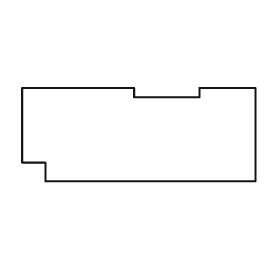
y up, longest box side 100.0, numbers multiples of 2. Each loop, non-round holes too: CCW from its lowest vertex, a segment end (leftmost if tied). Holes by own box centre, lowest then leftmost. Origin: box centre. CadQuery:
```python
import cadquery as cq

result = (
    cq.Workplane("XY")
    .moveTo(-40.0, -20.0)
    .lineTo(50.0, -20.0)
    .lineTo(50.0, 20.0)
    .lineTo(26.0, 20.0)
    .lineTo(26.0, 16.0)
    .lineTo(-2.0, 16.0)
    .lineTo(-2.0, 20.0)
    .lineTo(-50.0, 20.0)
    .lineTo(-50.0, -12.0)
    .lineTo(-40.0, -12.0)
    .close()
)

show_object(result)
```